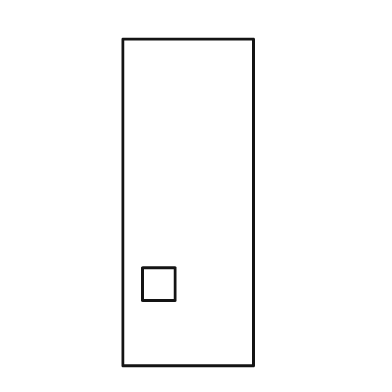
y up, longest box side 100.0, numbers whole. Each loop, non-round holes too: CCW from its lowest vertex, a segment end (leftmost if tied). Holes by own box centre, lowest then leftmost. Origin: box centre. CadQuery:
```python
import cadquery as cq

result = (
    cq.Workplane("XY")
    .moveTo(-20.0, -50.0)
    .lineTo(20.0, -50.0)
    .lineTo(20.0, 50.0)
    .lineTo(-20.0, 50.0)
    .close()
    .moveTo(-14.0, -30.0)
    .lineTo(-4.0, -30.0)
    .lineTo(-4.0, -20.0)
    .lineTo(-14.0, -20.0)
    .close()
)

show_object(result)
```